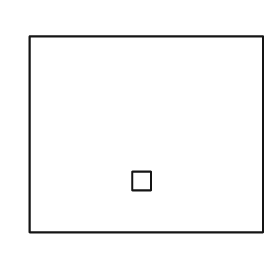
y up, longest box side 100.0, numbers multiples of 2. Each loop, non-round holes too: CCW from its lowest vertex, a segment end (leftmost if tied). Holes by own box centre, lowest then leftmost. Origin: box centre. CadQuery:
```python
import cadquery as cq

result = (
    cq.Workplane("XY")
    .moveTo(-50.0, -42.0)
    .lineTo(50.0, -42.0)
    .lineTo(50.0, 42.0)
    .lineTo(-50.0, 42.0)
    .close()
    .moveTo(-6.0, -24.0)
    .lineTo(2.0, -24.0)
    .lineTo(2.0, -16.0)
    .lineTo(-6.0, -16.0)
    .close()
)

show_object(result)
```